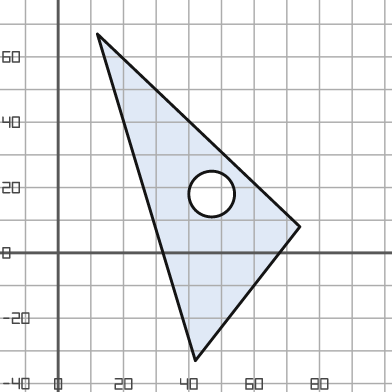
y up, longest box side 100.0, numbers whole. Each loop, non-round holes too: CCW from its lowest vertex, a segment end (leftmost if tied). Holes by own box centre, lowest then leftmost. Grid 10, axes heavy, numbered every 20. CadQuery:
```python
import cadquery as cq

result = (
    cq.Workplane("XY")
    .moveTo(42.0, -33.0)
    .lineTo(74.0, 8.0)
    .lineTo(12.0, 67.0)
    .close()
    .moveTo(47.0, 18.0)
    .circle(7.0)
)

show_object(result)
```